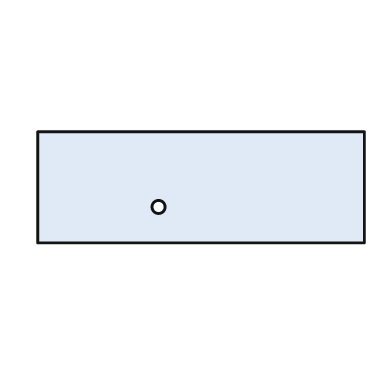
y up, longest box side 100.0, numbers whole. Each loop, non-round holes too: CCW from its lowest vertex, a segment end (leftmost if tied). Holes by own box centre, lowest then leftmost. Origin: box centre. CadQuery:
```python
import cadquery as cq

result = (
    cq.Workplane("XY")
    .moveTo(-50.0, -17.0)
    .lineTo(50.0, -17.0)
    .lineTo(50.0, 17.0)
    .lineTo(-50.0, 17.0)
    .close()
    .moveTo(-13.0, -6.0)
    .circle(2.0)
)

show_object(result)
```